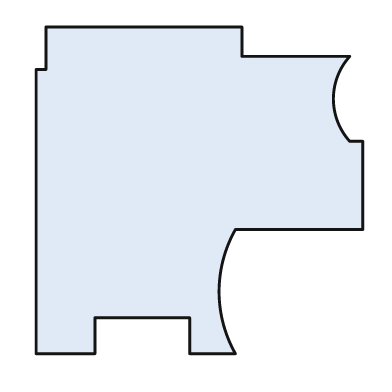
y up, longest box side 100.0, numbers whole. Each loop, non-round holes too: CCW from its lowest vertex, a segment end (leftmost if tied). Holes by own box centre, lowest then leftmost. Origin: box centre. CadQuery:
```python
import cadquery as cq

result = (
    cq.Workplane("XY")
    .moveTo(-50.0, -50.0)
    .lineTo(-32.0, -50.0)
    .lineTo(-32.0, -39.0)
    .lineTo(-3.0, -39.0)
    .lineTo(-3.0, -50.0)
    .lineTo(11.0, -50.0)
    .threePointArc((6.0, -31.0), (11.0, -12.0))
    .lineTo(50.0, -12.0)
    .lineTo(50.0, 15.0)
    .lineTo(46.0, 15.0)
    .threePointArc((41.0, 28.0), (46.0, 41.0))
    .lineTo(13.0, 41.0)
    .lineTo(13.0, 50.0)
    .lineTo(-47.0, 50.0)
    .lineTo(-47.0, 37.0)
    .lineTo(-50.0, 37.0)
    .close()
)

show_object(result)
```